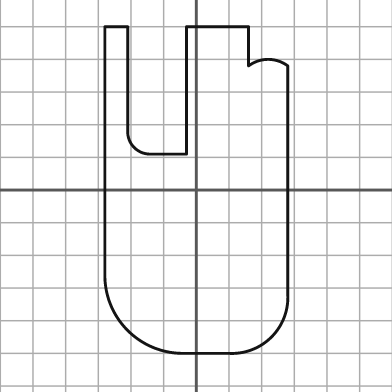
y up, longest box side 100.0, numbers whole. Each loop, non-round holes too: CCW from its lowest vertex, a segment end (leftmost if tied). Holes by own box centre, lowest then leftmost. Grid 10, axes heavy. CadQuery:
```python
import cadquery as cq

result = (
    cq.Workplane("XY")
    .moveTo(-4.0, -50.0)
    .lineTo(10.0, -50.0)
    .threePointArc((23.0, -45.0), (28.0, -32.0))
    .lineTo(28.0, 38.0)
    .threePointArc((22.0, 40.0), (16.0, 38.0))
    .lineTo(16.0, 50.0)
    .lineTo(-3.0, 50.0)
    .lineTo(-3.0, 11.0)
    .lineTo(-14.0, 11.0)
    .threePointArc((-19.0, 13.0), (-21.0, 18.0))
    .lineTo(-21.0, 50.0)
    .lineTo(-28.0, 50.0)
    .lineTo(-28.0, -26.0)
    .threePointArc((-21.0, -43.0), (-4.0, -50.0))
    .close()
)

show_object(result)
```